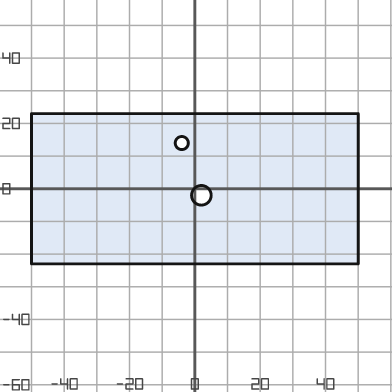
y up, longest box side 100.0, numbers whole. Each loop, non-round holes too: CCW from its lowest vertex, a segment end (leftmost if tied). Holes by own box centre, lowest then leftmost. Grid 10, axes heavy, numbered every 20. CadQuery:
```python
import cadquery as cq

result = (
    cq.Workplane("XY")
    .moveTo(-50.0, -23.0)
    .lineTo(50.0, -23.0)
    .lineTo(50.0, 23.0)
    .lineTo(-50.0, 23.0)
    .close()
    .moveTo(2.0, -2.0)
    .circle(3.0)
    .moveTo(-4.0, 14.0)
    .circle(2.0)
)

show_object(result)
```